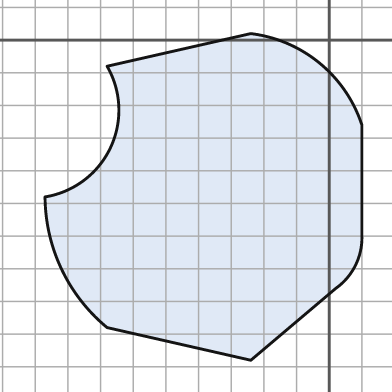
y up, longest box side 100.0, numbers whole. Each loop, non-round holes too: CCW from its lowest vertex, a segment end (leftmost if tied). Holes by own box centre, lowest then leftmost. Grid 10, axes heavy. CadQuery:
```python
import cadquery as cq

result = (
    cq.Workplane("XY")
    .moveTo(-24.0, -98.0)
    .lineTo(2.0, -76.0)
    .threePointArc((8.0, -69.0), (10.0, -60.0))
    .lineTo(10.0, -26.0)
    .threePointArc((-3.0, -7.0), (-24.0, 2.0))
    .lineTo(-68.0, -8.0)
    .threePointArc((-67.0, -33.0), (-87.0, -48.0))
    .threePointArc((-82.0, -70.0), (-68.0, -88.0))
    .close()
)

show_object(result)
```